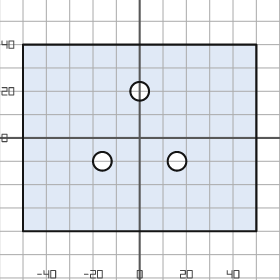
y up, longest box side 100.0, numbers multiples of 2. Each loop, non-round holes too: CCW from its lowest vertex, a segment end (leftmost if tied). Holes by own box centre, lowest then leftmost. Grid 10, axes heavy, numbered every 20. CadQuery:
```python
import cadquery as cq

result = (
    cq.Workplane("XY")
    .moveTo(-50.0, -40.0)
    .lineTo(50.0, -40.0)
    .lineTo(50.0, 40.0)
    .lineTo(-50.0, 40.0)
    .close()
    .moveTo(-16.0, -10.0)
    .circle(4.0)
    .moveTo(16.0, -10.0)
    .circle(4.0)
    .moveTo(0.0, 20.0)
    .circle(4.0)
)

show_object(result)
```